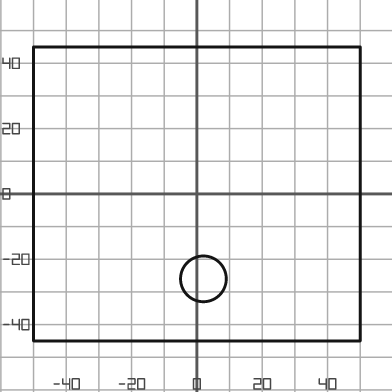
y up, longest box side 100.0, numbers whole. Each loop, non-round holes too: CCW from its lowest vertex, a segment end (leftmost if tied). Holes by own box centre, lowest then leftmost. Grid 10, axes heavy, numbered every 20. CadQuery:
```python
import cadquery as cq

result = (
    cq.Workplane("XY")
    .moveTo(-50.0, -45.0)
    .lineTo(50.0, -45.0)
    .lineTo(50.0, 45.0)
    .lineTo(-50.0, 45.0)
    .close()
    .moveTo(2.0, -26.0)
    .circle(7.0)
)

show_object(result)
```